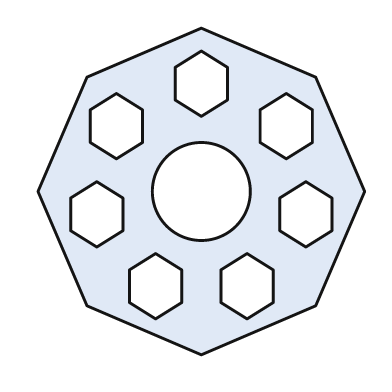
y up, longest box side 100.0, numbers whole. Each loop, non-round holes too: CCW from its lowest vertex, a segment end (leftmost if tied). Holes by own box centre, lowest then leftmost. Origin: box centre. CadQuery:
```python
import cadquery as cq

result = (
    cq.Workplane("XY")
    .moveTo(0.0, -50.0)
    .lineTo(35.0, -35.0)
    .lineTo(50.0, 0.0)
    .lineTo(35.0, 35.0)
    .lineTo(0.0, 50.0)
    .lineTo(-35.0, 35.0)
    .lineTo(-50.0, 0.0)
    .lineTo(-35.0, -35.0)
    .close()
    .moveTo(-14.0, -39.0)
    .lineTo(-6.0, -34.0)
    .lineTo(-6.0, -24.0)
    .lineTo(-14.0, -19.0)
    .lineTo(-22.0, -24.0)
    .lineTo(-22.0, -34.0)
    .close()
    .moveTo(14.0, -39.0)
    .lineTo(22.0, -34.0)
    .lineTo(22.0, -24.0)
    .lineTo(14.0, -19.0)
    .lineTo(6.0, -24.0)
    .lineTo(6.0, -34.0)
    .close()
    .moveTo(-32.0, -17.0)
    .lineTo(-24.0, -12.0)
    .lineTo(-24.0, -2.0)
    .lineTo(-32.0, 3.0)
    .lineTo(-40.0, -2.0)
    .lineTo(-40.0, -12.0)
    .close()
    .moveTo(32.0, -17.0)
    .lineTo(40.0, -12.0)
    .lineTo(40.0, -2.0)
    .lineTo(32.0, 3.0)
    .lineTo(24.0, -2.0)
    .lineTo(24.0, -12.0)
    .close()
    .moveTo(0.0, 0.0)
    .circle(15.0)
    .moveTo(-26.0, 10.0)
    .lineTo(-18.0, 15.0)
    .lineTo(-18.0, 25.0)
    .lineTo(-26.0, 30.0)
    .lineTo(-34.0, 25.0)
    .lineTo(-34.0, 15.0)
    .close()
    .moveTo(26.0, 10.0)
    .lineTo(34.0, 15.0)
    .lineTo(34.0, 25.0)
    .lineTo(26.0, 30.0)
    .lineTo(18.0, 25.0)
    .lineTo(18.0, 15.0)
    .close()
    .moveTo(0.0, 23.0)
    .lineTo(8.0, 28.0)
    .lineTo(8.0, 38.0)
    .lineTo(0.0, 43.0)
    .lineTo(-8.0, 38.0)
    .lineTo(-8.0, 28.0)
    .close()
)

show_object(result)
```